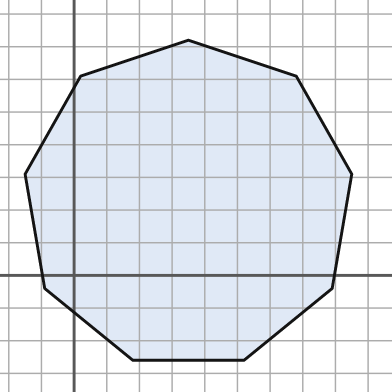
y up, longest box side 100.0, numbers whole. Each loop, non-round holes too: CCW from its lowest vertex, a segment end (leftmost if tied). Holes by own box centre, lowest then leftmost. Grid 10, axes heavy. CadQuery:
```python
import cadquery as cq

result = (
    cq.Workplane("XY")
    .moveTo(18.0, -26.0)
    .lineTo(52.0, -26.0)
    .lineTo(79.0, -4.0)
    .lineTo(85.0, 31.0)
    .lineTo(68.0, 61.0)
    .lineTo(35.0, 72.0)
    .lineTo(2.0, 61.0)
    .lineTo(-15.0, 31.0)
    .lineTo(-9.0, -4.0)
    .close()
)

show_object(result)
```